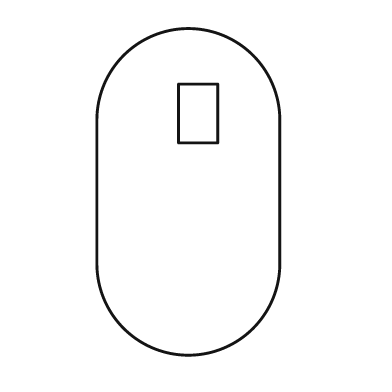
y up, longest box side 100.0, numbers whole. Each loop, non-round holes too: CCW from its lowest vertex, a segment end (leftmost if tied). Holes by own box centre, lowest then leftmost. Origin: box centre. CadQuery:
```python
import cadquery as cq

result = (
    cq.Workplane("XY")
    .moveTo(-28.0, -22.0)
    .threePointArc((0.0, -50.0), (28.0, -22.0))
    .lineTo(28.0, 22.0)
    .threePointArc((0.0, 50.0), (-28.0, 22.0))
    .close()
    .moveTo(-3.0, 15.0)
    .lineTo(9.0, 15.0)
    .lineTo(9.0, 33.0)
    .lineTo(-3.0, 33.0)
    .close()
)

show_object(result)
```